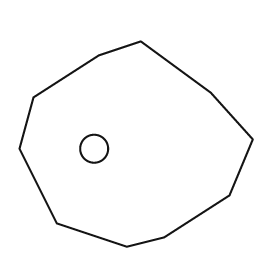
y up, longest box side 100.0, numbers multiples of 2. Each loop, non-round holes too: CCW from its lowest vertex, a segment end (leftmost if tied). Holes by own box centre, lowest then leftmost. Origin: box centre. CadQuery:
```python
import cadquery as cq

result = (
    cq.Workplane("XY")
    .moveTo(-4.0, -44.0)
    .lineTo(12.0, -40.0)
    .lineTo(40.0, -22.0)
    .lineTo(50.0, 2.0)
    .lineTo(32.0, 22.0)
    .lineTo(2.0, 44.0)
    .lineTo(-16.0, 38.0)
    .lineTo(-44.0, 20.0)
    .lineTo(-50.0, -2.0)
    .lineTo(-34.0, -34.0)
    .close()
    .moveTo(-18.0, -2.0)
    .circle(6.0)
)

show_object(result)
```